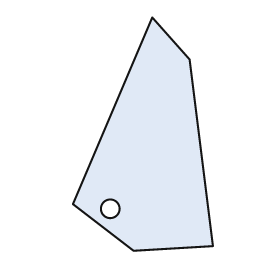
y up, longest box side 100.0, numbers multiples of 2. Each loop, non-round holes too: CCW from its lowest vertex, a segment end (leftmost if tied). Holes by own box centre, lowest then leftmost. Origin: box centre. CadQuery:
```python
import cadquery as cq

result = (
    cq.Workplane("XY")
    .moveTo(-4.0, -50.0)
    .lineTo(30.0, -48.0)
    .lineTo(20.0, 32.0)
    .lineTo(4.0, 50.0)
    .lineTo(-30.0, -30.0)
    .close()
    .moveTo(-14.0, -32.0)
    .circle(4.0)
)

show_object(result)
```